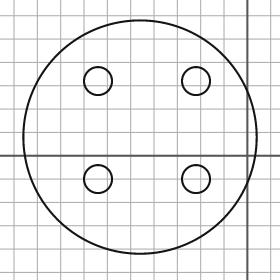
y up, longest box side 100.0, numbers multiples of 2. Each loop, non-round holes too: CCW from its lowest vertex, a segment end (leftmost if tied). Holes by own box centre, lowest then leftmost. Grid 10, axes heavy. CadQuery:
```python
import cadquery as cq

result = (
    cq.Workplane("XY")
    .moveTo(-46.0, 8.0)
    .circle(50.0)
    .moveTo(-64.0, -10.0)
    .circle(6.0)
    .moveTo(-22.0, -10.0)
    .circle(6.0)
    .moveTo(-64.0, 32.0)
    .circle(6.0)
    .moveTo(-22.0, 32.0)
    .circle(6.0)
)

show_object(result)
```